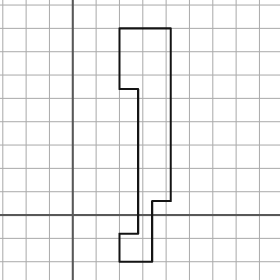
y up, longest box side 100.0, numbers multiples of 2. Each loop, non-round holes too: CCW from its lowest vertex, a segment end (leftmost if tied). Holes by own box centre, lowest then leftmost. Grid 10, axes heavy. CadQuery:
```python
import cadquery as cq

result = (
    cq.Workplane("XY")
    .moveTo(20.0, -20.0)
    .lineTo(34.0, -20.0)
    .lineTo(34.0, 6.0)
    .lineTo(42.0, 6.0)
    .lineTo(42.0, 80.0)
    .lineTo(20.0, 80.0)
    .lineTo(20.0, 54.0)
    .lineTo(28.0, 54.0)
    .lineTo(28.0, -8.0)
    .lineTo(20.0, -8.0)
    .close()
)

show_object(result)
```